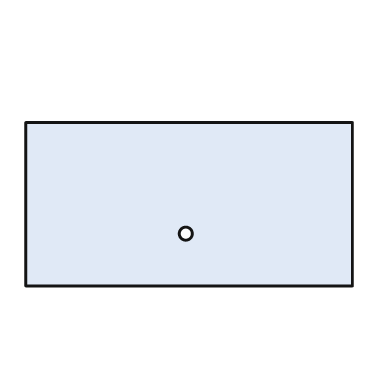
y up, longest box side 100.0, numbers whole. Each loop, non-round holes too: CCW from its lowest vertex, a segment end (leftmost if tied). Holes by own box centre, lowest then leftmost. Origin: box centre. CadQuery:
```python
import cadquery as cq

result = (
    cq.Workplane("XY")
    .moveTo(-50.0, -25.0)
    .lineTo(50.0, -25.0)
    .lineTo(50.0, 25.0)
    .lineTo(-50.0, 25.0)
    .close()
    .moveTo(-1.0, -9.0)
    .circle(2.0)
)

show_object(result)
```